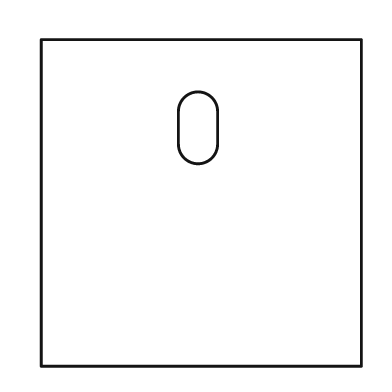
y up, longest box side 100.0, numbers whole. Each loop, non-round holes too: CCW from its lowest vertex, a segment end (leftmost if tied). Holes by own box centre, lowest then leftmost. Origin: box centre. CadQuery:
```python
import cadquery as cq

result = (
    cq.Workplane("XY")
    .moveTo(-49.0, -50.0)
    .lineTo(49.0, -50.0)
    .lineTo(49.0, 50.0)
    .lineTo(-49.0, 50.0)
    .close()
    .moveTo(-7.0, 18.0)
    .threePointArc((-1.0, 12.0), (5.0, 18.0))
    .lineTo(5.0, 28.0)
    .threePointArc((-1.0, 34.0), (-7.0, 28.0))
    .close()
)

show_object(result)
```